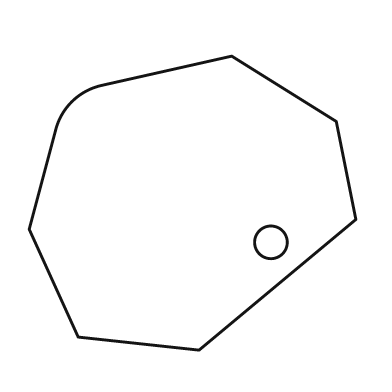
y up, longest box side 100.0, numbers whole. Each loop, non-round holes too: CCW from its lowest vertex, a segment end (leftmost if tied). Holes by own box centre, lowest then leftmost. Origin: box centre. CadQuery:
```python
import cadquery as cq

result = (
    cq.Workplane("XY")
    .moveTo(2.0, -45.0)
    .lineTo(50.0, -5.0)
    .lineTo(44.0, 25.0)
    .lineTo(12.0, 45.0)
    .lineTo(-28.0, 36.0)
    .threePointArc((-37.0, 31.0), (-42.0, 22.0))
    .lineTo(-50.0, -8.0)
    .lineTo(-35.0, -41.0)
    .close()
    .moveTo(24.0, -12.0)
    .circle(5.0)
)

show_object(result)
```